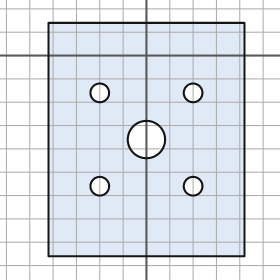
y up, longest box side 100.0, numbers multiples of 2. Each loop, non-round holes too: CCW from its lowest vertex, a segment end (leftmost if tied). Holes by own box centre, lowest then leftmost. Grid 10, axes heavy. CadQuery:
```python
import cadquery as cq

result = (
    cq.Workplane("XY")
    .moveTo(-42.0, -86.0)
    .lineTo(42.0, -86.0)
    .lineTo(42.0, 14.0)
    .lineTo(-42.0, 14.0)
    .close()
    .moveTo(-20.0, -56.0)
    .circle(4.0)
    .moveTo(20.0, -56.0)
    .circle(4.0)
    .moveTo(0.0, -36.0)
    .circle(8.0)
    .moveTo(-20.0, -16.0)
    .circle(4.0)
    .moveTo(20.0, -16.0)
    .circle(4.0)
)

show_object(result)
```